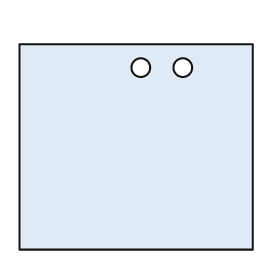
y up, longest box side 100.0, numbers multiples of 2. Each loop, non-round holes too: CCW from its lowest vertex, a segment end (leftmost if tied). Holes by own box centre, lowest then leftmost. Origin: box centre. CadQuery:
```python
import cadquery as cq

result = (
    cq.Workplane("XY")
    .moveTo(-50.0, -44.0)
    .lineTo(50.0, -44.0)
    .lineTo(50.0, 44.0)
    .lineTo(-50.0, 44.0)
    .close()
    .moveTo(2.0, 34.0)
    .circle(4.0)
    .moveTo(20.0, 34.0)
    .circle(4.0)
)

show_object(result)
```